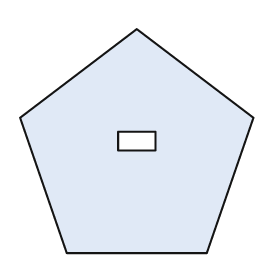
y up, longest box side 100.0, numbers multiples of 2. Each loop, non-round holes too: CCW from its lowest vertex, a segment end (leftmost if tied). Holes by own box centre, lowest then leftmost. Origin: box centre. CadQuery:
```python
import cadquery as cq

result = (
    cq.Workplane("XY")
    .moveTo(-30.0, -48.0)
    .lineTo(30.0, -48.0)
    .lineTo(50.0, 10.0)
    .lineTo(0.0, 48.0)
    .lineTo(-50.0, 10.0)
    .close()
    .moveTo(-8.0, -4.0)
    .lineTo(8.0, -4.0)
    .lineTo(8.0, 4.0)
    .lineTo(-8.0, 4.0)
    .close()
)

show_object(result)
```